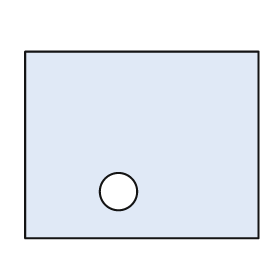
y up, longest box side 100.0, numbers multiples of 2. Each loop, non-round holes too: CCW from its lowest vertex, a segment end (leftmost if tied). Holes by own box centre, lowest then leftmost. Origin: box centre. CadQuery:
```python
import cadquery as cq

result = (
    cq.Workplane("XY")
    .moveTo(-50.0, -40.0)
    .lineTo(50.0, -40.0)
    .lineTo(50.0, 40.0)
    .lineTo(-50.0, 40.0)
    .close()
    .moveTo(-10.0, -20.0)
    .circle(8.0)
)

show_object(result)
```